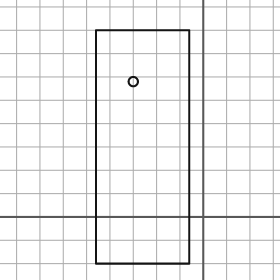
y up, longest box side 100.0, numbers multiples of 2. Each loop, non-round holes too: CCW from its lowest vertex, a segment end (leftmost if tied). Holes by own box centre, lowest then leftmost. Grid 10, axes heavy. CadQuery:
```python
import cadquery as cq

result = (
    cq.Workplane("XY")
    .moveTo(-46.0, -20.0)
    .lineTo(-6.0, -20.0)
    .lineTo(-6.0, 80.0)
    .lineTo(-46.0, 80.0)
    .close()
    .moveTo(-30.0, 58.0)
    .circle(2.0)
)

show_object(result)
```